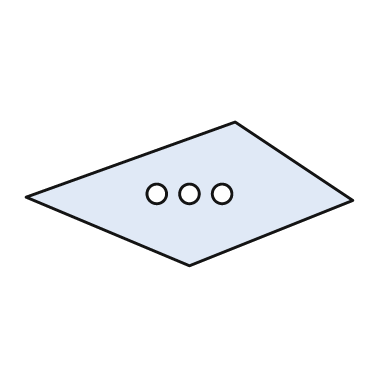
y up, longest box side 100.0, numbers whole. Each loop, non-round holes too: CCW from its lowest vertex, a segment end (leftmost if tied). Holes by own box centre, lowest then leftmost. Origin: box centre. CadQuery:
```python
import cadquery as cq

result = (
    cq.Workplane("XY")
    .moveTo(0.0, -22.0)
    .lineTo(50.0, -2.0)
    .lineTo(14.0, 22.0)
    .lineTo(-50.0, -1.0)
    .close()
    .moveTo(-10.0, 0.0)
    .circle(3.0)
    .moveTo(0.0, 0.0)
    .circle(3.0)
    .moveTo(10.0, 0.0)
    .circle(3.0)
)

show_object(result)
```